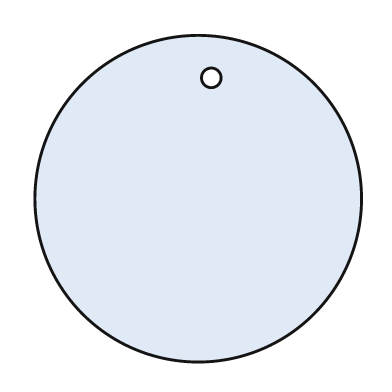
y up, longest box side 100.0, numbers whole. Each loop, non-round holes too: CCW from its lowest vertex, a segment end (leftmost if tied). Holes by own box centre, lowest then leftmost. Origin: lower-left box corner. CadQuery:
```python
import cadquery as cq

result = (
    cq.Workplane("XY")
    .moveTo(50.0, 50.0)
    .circle(50.0)
    .moveTo(54.0, 87.0)
    .circle(3.0)
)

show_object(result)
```